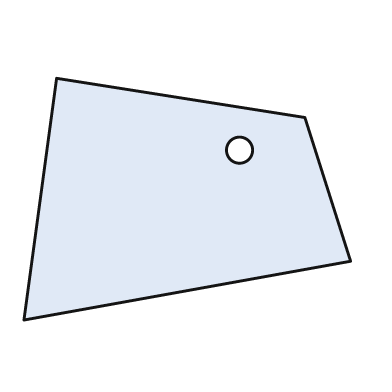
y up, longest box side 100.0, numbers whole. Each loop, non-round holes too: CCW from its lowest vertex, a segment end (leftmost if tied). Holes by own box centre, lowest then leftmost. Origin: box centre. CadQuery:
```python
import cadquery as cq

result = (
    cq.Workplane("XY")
    .moveTo(-50.0, -37.0)
    .lineTo(50.0, -19.0)
    .lineTo(36.0, 25.0)
    .lineTo(-40.0, 37.0)
    .close()
    .moveTo(16.0, 15.0)
    .circle(4.0)
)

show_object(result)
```